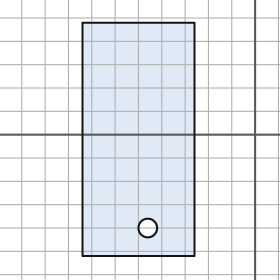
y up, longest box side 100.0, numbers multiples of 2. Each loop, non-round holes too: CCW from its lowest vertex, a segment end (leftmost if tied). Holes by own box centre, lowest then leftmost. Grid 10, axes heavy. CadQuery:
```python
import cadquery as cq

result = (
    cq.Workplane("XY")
    .moveTo(-74.0, -52.0)
    .lineTo(-26.0, -52.0)
    .lineTo(-26.0, 48.0)
    .lineTo(-74.0, 48.0)
    .close()
    .moveTo(-46.0, -40.0)
    .circle(4.0)
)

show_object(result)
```